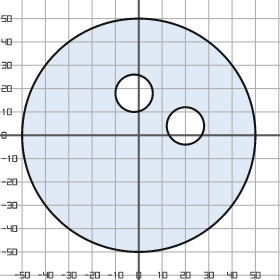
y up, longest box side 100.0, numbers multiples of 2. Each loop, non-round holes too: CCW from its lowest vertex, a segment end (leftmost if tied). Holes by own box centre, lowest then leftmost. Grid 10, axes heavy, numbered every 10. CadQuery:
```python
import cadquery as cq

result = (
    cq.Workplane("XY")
    .moveTo(0.0, 0.0)
    .circle(50.0)
    .moveTo(20.0, 4.0)
    .circle(8.0)
    .moveTo(-2.0, 18.0)
    .circle(8.0)
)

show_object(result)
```